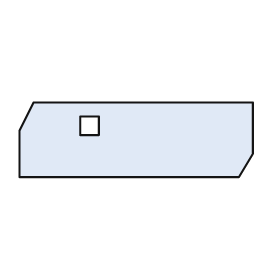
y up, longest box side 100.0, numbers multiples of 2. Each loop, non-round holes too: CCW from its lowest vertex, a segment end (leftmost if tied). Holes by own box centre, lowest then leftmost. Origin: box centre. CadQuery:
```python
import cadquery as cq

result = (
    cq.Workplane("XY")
    .moveTo(-50.0, -16.0)
    .lineTo(44.0, -16.0)
    .lineTo(50.0, -6.0)
    .lineTo(50.0, 16.0)
    .lineTo(-44.0, 16.0)
    .lineTo(-50.0, 4.0)
    .close()
    .moveTo(-24.0, 2.0)
    .lineTo(-16.0, 2.0)
    .lineTo(-16.0, 10.0)
    .lineTo(-24.0, 10.0)
    .close()
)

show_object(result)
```